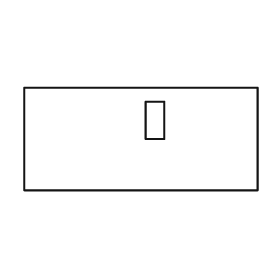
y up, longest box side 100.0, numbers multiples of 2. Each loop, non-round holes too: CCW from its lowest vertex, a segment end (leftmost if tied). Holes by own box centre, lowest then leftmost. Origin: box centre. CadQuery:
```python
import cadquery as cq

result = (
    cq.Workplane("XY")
    .moveTo(-50.0, -22.0)
    .lineTo(50.0, -22.0)
    .lineTo(50.0, 22.0)
    .lineTo(-50.0, 22.0)
    .close()
    .moveTo(2.0, 0.0)
    .lineTo(10.0, 0.0)
    .lineTo(10.0, 16.0)
    .lineTo(2.0, 16.0)
    .close()
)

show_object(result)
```